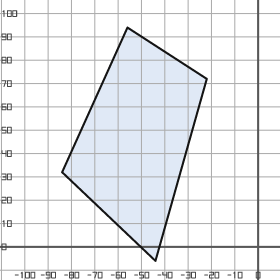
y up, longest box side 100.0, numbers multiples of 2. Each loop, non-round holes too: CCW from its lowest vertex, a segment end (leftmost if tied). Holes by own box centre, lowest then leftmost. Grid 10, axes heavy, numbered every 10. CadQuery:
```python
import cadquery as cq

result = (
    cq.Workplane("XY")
    .moveTo(-44.0, -6.0)
    .lineTo(-22.0, 72.0)
    .lineTo(-56.0, 94.0)
    .lineTo(-84.0, 32.0)
    .close()
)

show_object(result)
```